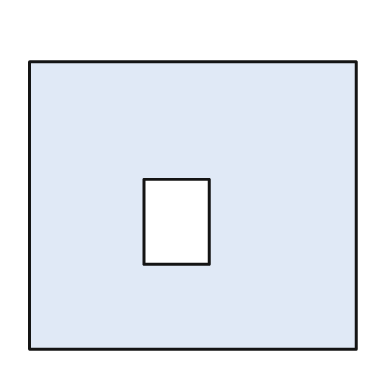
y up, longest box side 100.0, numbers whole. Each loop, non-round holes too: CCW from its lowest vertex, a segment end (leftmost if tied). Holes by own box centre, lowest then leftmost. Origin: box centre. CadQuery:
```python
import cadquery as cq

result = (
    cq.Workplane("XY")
    .moveTo(-50.0, -44.0)
    .lineTo(50.0, -44.0)
    .lineTo(50.0, 44.0)
    .lineTo(-50.0, 44.0)
    .close()
    .moveTo(-15.0, -18.0)
    .lineTo(5.0, -18.0)
    .lineTo(5.0, 8.0)
    .lineTo(-15.0, 8.0)
    .close()
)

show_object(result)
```